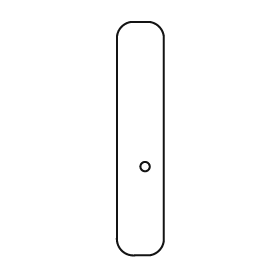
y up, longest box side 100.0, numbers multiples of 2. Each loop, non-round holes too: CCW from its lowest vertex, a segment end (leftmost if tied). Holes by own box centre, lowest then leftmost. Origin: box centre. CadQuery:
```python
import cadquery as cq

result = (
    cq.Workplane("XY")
    .moveTo(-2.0, -50.0)
    .lineTo(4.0, -50.0)
    .threePointArc((8.0, -48.0), (10.0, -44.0))
    .lineTo(10.0, 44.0)
    .threePointArc((8.0, 48.0), (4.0, 50.0))
    .lineTo(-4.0, 50.0)
    .threePointArc((-8.0, 48.0), (-10.0, 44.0))
    .lineTo(-10.0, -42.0)
    .threePointArc((-8.0, -48.0), (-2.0, -50.0))
    .close()
    .moveTo(2.0, -12.0)
    .circle(2.0)
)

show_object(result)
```